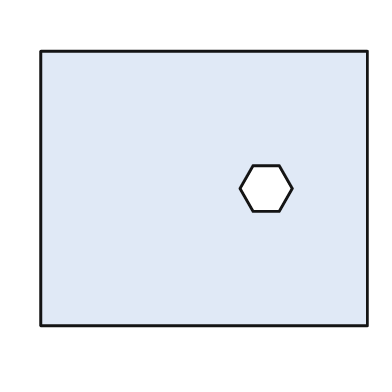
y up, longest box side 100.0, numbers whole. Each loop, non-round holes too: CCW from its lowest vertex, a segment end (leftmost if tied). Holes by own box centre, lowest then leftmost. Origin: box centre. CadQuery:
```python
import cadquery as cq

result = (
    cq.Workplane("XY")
    .moveTo(-50.0, -42.0)
    .lineTo(50.0, -42.0)
    .lineTo(50.0, 42.0)
    .lineTo(-50.0, 42.0)
    .close()
    .moveTo(15.0, -7.0)
    .lineTo(23.0, -7.0)
    .lineTo(27.0, 0.0)
    .lineTo(23.0, 7.0)
    .lineTo(15.0, 7.0)
    .lineTo(11.0, 0.0)
    .close()
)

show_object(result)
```